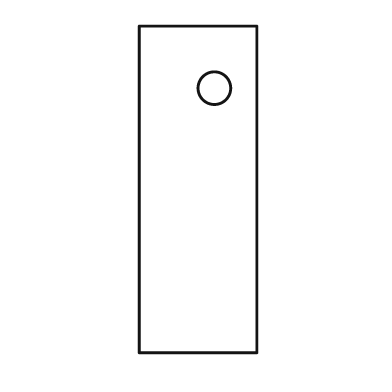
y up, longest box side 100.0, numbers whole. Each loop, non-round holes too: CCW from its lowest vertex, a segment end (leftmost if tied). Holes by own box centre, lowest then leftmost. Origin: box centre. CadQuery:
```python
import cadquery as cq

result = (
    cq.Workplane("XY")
    .moveTo(-18.0, -50.0)
    .lineTo(18.0, -50.0)
    .lineTo(18.0, 50.0)
    .lineTo(-18.0, 50.0)
    .close()
    .moveTo(5.0, 31.0)
    .circle(5.0)
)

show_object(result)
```